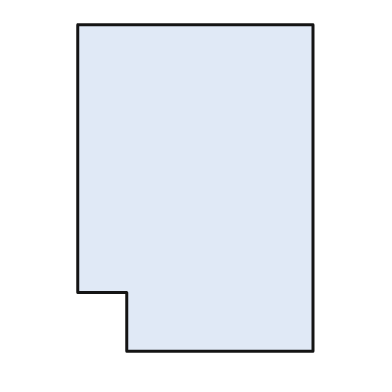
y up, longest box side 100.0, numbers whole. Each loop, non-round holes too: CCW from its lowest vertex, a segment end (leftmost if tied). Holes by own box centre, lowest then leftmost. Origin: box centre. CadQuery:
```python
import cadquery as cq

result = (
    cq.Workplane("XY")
    .moveTo(-21.0, -50.0)
    .lineTo(36.0, -50.0)
    .lineTo(36.0, 50.0)
    .lineTo(-36.0, 50.0)
    .lineTo(-36.0, -32.0)
    .lineTo(-21.0, -32.0)
    .close()
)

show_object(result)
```